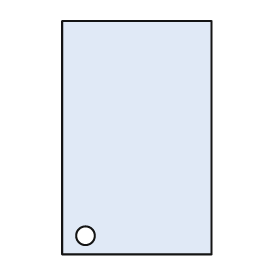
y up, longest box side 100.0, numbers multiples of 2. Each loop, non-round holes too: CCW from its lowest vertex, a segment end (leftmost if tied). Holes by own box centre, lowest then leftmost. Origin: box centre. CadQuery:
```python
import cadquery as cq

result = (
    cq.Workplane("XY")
    .moveTo(-32.0, -50.0)
    .lineTo(32.0, -50.0)
    .lineTo(32.0, 50.0)
    .lineTo(-32.0, 50.0)
    .close()
    .moveTo(-22.0, -42.0)
    .circle(4.0)
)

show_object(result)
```